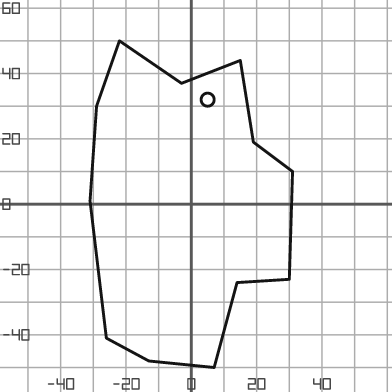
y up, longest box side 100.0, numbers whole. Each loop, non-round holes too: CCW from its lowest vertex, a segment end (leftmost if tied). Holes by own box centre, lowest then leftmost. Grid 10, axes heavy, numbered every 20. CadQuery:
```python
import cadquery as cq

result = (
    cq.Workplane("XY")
    .moveTo(7.0, -50.0)
    .lineTo(14.0, -24.0)
    .lineTo(30.0, -23.0)
    .lineTo(31.0, 10.0)
    .lineTo(19.0, 19.0)
    .lineTo(15.0, 44.0)
    .lineTo(-3.0, 37.0)
    .lineTo(-22.0, 50.0)
    .lineTo(-29.0, 30.0)
    .lineTo(-31.0, 1.0)
    .lineTo(-26.0, -41.0)
    .lineTo(-13.0, -48.0)
    .close()
    .moveTo(5.0, 32.0)
    .circle(2.0)
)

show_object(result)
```